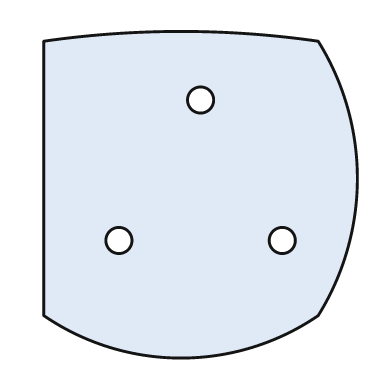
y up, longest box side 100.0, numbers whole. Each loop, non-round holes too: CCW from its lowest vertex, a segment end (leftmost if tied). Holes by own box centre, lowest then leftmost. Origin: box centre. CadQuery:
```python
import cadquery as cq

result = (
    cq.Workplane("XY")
    .moveTo(-48.0, -37.0)
    .threePointArc((-6.0, -50.0), (36.0, -37.0))
    .threePointArc((48.0, 5.0), (36.0, 47.0))
    .threePointArc((-6.0, 50.0), (-48.0, 47.0))
    .close()
    .moveTo(-25.0, -14.0)
    .circle(4.0)
    .moveTo(25.0, -14.0)
    .circle(4.0)
    .moveTo(0.0, 29.0)
    .circle(4.0)
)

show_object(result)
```